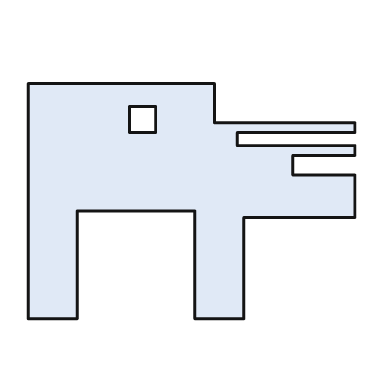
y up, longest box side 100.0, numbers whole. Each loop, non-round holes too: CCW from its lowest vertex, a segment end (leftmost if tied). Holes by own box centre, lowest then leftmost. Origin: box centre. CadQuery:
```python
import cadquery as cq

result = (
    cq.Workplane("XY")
    .moveTo(-50.0, -36.0)
    .lineTo(-35.0, -36.0)
    .lineTo(-35.0, -3.0)
    .lineTo(1.0, -3.0)
    .lineTo(1.0, -36.0)
    .lineTo(16.0, -36.0)
    .lineTo(16.0, -5.0)
    .lineTo(50.0, -5.0)
    .lineTo(50.0, 8.0)
    .lineTo(31.0, 8.0)
    .lineTo(31.0, 14.0)
    .lineTo(50.0, 14.0)
    .lineTo(50.0, 17.0)
    .lineTo(14.0, 17.0)
    .lineTo(14.0, 21.0)
    .lineTo(50.0, 21.0)
    .lineTo(50.0, 24.0)
    .lineTo(7.0, 24.0)
    .lineTo(7.0, 36.0)
    .lineTo(-50.0, 36.0)
    .close()
    .moveTo(-19.0, 21.0)
    .lineTo(-11.0, 21.0)
    .lineTo(-11.0, 29.0)
    .lineTo(-19.0, 29.0)
    .close()
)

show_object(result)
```